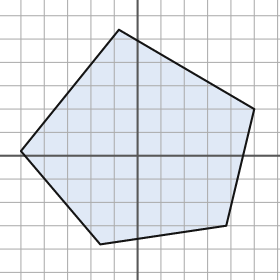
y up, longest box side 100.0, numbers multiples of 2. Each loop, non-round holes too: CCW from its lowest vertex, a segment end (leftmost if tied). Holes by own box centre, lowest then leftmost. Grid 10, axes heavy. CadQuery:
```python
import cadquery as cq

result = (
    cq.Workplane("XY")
    .moveTo(-16.0, -38.0)
    .lineTo(38.0, -30.0)
    .lineTo(50.0, 20.0)
    .lineTo(-8.0, 54.0)
    .lineTo(-50.0, 2.0)
    .close()
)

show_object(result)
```